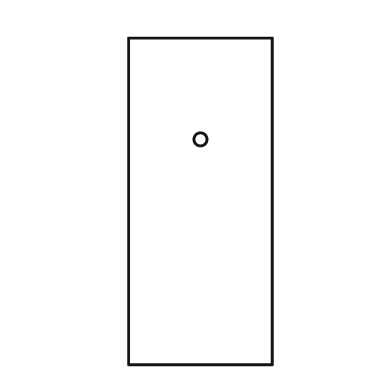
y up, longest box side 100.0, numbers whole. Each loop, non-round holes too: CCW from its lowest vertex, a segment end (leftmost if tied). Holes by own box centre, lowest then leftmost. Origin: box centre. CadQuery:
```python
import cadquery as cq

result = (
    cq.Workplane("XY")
    .moveTo(-22.0, -50.0)
    .lineTo(22.0, -50.0)
    .lineTo(22.0, 50.0)
    .lineTo(-22.0, 50.0)
    .close()
    .moveTo(0.0, 19.0)
    .circle(2.0)
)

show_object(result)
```